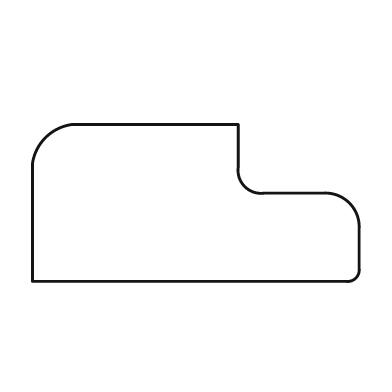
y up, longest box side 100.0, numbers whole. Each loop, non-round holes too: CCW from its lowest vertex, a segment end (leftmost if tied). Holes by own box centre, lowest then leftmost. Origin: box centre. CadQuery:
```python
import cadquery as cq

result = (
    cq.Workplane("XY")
    .moveTo(-50.0, -24.0)
    .lineTo(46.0, -24.0)
    .threePointArc((49.0, -23.0), (50.0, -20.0))
    .lineTo(50.0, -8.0)
    .threePointArc((47.0, 0.0), (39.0, 3.0))
    .lineTo(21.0, 3.0)
    .threePointArc((15.0, 5.0), (13.0, 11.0))
    .lineTo(13.0, 24.0)
    .lineTo(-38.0, 24.0)
    .threePointArc((-46.0, 20.0), (-50.0, 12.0))
    .close()
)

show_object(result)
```